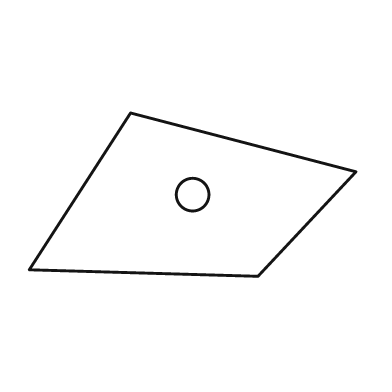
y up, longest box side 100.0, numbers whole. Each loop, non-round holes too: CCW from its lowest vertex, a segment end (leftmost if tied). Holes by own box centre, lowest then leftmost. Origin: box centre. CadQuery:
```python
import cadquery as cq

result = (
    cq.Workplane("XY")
    .moveTo(20.0, -25.0)
    .lineTo(50.0, 7.0)
    .lineTo(-19.0, 25.0)
    .lineTo(-50.0, -23.0)
    .close()
    .moveTo(0.0, 0.0)
    .circle(5.0)
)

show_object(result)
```